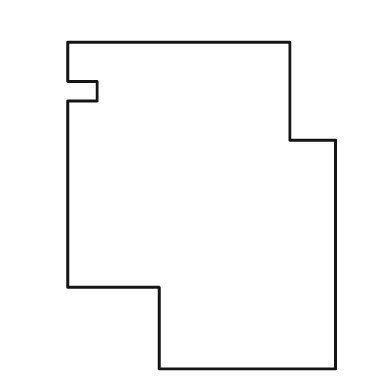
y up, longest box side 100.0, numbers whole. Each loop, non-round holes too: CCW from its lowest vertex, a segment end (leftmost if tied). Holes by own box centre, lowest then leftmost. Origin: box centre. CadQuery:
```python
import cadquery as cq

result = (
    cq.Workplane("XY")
    .moveTo(-13.0, -50.0)
    .lineTo(41.0, -50.0)
    .lineTo(41.0, 20.0)
    .lineTo(27.0, 20.0)
    .lineTo(27.0, 50.0)
    .lineTo(-41.0, 50.0)
    .lineTo(-41.0, 38.0)
    .lineTo(-32.0, 38.0)
    .lineTo(-32.0, 32.0)
    .lineTo(-41.0, 32.0)
    .lineTo(-41.0, -25.0)
    .lineTo(-13.0, -25.0)
    .close()
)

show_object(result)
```